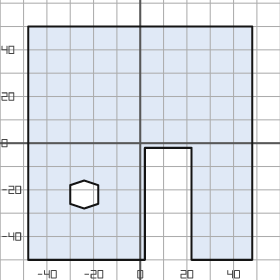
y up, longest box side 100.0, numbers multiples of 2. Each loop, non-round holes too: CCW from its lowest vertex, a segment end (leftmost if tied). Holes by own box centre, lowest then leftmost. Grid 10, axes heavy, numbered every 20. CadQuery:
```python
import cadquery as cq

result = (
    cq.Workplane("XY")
    .moveTo(-48.0, -50.0)
    .lineTo(2.0, -50.0)
    .lineTo(2.0, -2.0)
    .lineTo(22.0, -2.0)
    .lineTo(22.0, -50.0)
    .lineTo(48.0, -50.0)
    .lineTo(48.0, 50.0)
    .lineTo(-48.0, 50.0)
    .close()
    .moveTo(-24.0, -28.0)
    .lineTo(-18.0, -26.0)
    .lineTo(-18.0, -18.0)
    .lineTo(-24.0, -16.0)
    .lineTo(-30.0, -18.0)
    .lineTo(-30.0, -26.0)
    .close()
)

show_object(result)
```